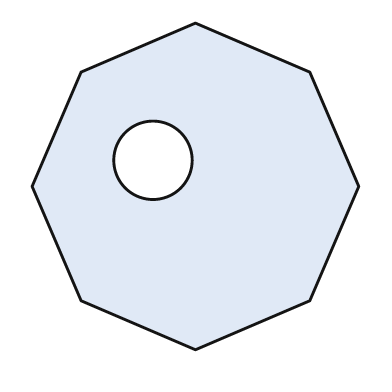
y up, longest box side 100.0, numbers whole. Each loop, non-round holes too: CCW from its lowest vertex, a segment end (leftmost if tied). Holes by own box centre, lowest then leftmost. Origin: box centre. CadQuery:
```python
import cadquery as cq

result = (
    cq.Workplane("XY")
    .moveTo(0.0, -50.0)
    .lineTo(35.0, -35.0)
    .lineTo(50.0, 0.0)
    .lineTo(35.0, 35.0)
    .lineTo(0.0, 50.0)
    .lineTo(-35.0, 35.0)
    .lineTo(-50.0, 0.0)
    .lineTo(-35.0, -35.0)
    .close()
    .moveTo(-13.0, 8.0)
    .circle(12.0)
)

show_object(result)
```